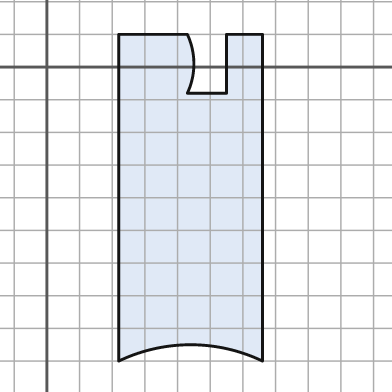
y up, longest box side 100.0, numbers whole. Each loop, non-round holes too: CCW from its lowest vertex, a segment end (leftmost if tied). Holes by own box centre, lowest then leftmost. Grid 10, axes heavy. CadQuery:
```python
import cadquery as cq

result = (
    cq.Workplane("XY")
    .moveTo(22.0, -90.0)
    .threePointArc((44.0, -85.0), (66.0, -90.0))
    .lineTo(66.0, 10.0)
    .lineTo(55.0, 10.0)
    .lineTo(55.0, -8.0)
    .lineTo(43.0, -8.0)
    .threePointArc((45.0, 1.0), (43.0, 10.0))
    .lineTo(22.0, 10.0)
    .close()
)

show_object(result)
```